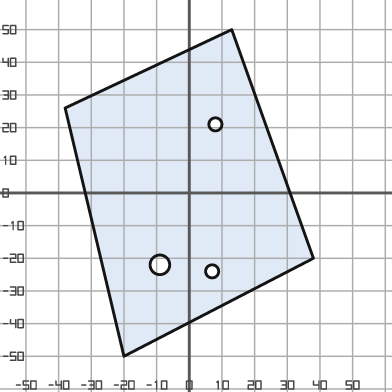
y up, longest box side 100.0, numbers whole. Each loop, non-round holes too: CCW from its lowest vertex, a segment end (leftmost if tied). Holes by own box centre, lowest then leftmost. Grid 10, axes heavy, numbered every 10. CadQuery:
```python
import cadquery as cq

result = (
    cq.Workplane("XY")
    .moveTo(-20.0, -50.0)
    .lineTo(38.0, -20.0)
    .lineTo(13.0, 50.0)
    .lineTo(-38.0, 26.0)
    .close()
    .moveTo(7.0, -24.0)
    .circle(2.0)
    .moveTo(-9.0, -22.0)
    .circle(3.0)
    .moveTo(8.0, 21.0)
    .circle(2.0)
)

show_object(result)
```